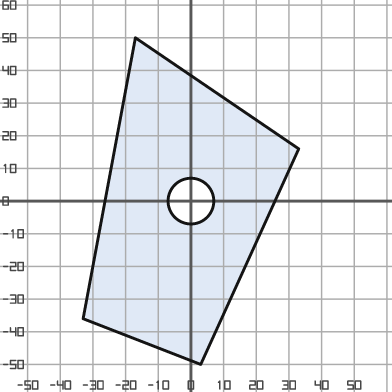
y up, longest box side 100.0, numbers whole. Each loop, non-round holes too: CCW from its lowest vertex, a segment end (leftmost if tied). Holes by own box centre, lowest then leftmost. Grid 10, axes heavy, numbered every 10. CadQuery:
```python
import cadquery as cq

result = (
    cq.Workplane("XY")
    .moveTo(3.0, -50.0)
    .lineTo(33.0, 16.0)
    .lineTo(-17.0, 50.0)
    .lineTo(-33.0, -36.0)
    .close()
    .moveTo(0.0, 0.0)
    .circle(7.0)
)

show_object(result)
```